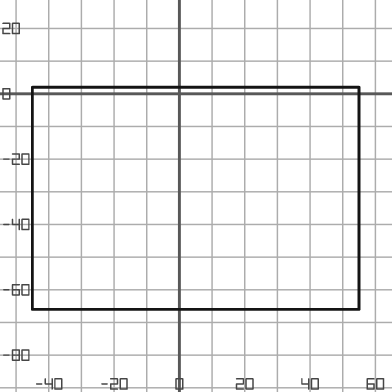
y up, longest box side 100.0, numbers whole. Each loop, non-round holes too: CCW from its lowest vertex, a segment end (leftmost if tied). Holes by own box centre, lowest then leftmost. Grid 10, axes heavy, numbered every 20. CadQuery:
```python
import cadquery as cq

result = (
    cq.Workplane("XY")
    .moveTo(-45.0, -66.0)
    .lineTo(55.0, -66.0)
    .lineTo(55.0, 2.0)
    .lineTo(-45.0, 2.0)
    .close()
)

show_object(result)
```